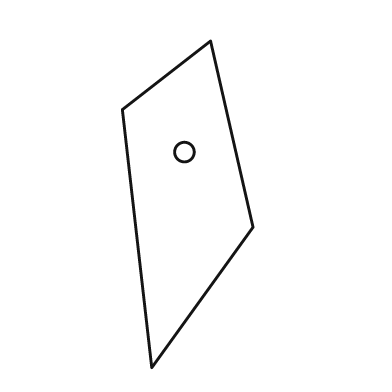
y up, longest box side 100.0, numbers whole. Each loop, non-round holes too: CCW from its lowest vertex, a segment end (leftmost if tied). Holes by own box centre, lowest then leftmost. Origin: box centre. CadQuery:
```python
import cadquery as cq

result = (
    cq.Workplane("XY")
    .moveTo(-11.0, -50.0)
    .lineTo(20.0, -7.0)
    .lineTo(7.0, 50.0)
    .lineTo(-20.0, 29.0)
    .close()
    .moveTo(-1.0, 16.0)
    .circle(3.0)
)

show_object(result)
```